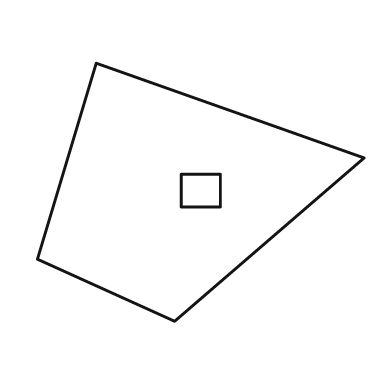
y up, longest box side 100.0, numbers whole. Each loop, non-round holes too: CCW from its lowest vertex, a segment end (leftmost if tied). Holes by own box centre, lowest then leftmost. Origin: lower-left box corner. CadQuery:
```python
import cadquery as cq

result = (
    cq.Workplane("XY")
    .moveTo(42.0, 0.0)
    .lineTo(100.0, 50.0)
    .lineTo(18.0, 79.0)
    .lineTo(0.0, 19.0)
    .close()
    .moveTo(44.0, 35.0)
    .lineTo(56.0, 35.0)
    .lineTo(56.0, 45.0)
    .lineTo(44.0, 45.0)
    .close()
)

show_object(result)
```